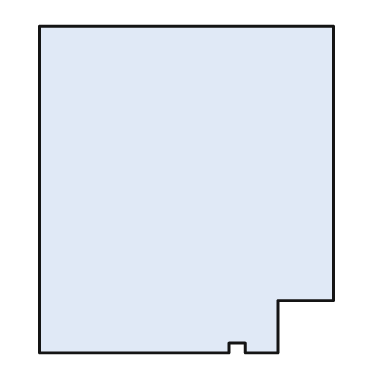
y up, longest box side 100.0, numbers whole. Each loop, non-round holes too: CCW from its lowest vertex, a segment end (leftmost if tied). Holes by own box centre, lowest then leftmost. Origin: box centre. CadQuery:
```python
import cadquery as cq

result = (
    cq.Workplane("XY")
    .moveTo(-45.0, -50.0)
    .lineTo(13.0, -50.0)
    .lineTo(13.0, -47.0)
    .lineTo(18.0, -47.0)
    .lineTo(18.0, -50.0)
    .lineTo(28.0, -50.0)
    .lineTo(28.0, -34.0)
    .lineTo(45.0, -34.0)
    .lineTo(45.0, 50.0)
    .lineTo(-45.0, 50.0)
    .close()
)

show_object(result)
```